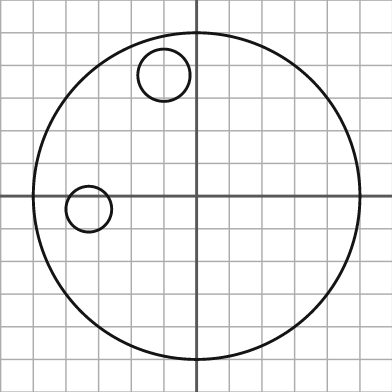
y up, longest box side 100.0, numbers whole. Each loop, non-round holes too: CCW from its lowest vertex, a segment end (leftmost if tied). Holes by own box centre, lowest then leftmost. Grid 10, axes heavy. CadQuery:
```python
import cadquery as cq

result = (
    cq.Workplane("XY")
    .moveTo(0.0, 0.0)
    .circle(50.0)
    .moveTo(-33.0, -4.0)
    .circle(7.0)
    .moveTo(-10.0, 37.0)
    .circle(8.0)
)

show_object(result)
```